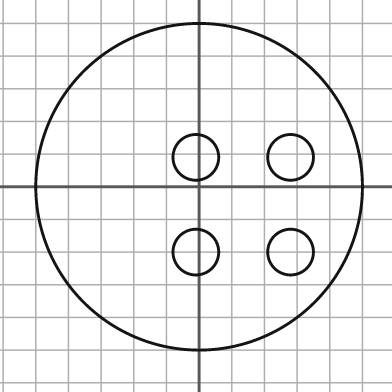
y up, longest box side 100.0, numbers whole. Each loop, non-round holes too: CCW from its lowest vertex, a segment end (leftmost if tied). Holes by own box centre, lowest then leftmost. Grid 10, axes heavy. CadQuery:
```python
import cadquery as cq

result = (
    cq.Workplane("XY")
    .moveTo(0.0, 0.0)
    .circle(50.0)
    .moveTo(-1.0, -20.0)
    .circle(7.0)
    .moveTo(28.0, -20.0)
    .circle(7.0)
    .moveTo(-1.0, 9.0)
    .circle(7.0)
    .moveTo(28.0, 9.0)
    .circle(7.0)
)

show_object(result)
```